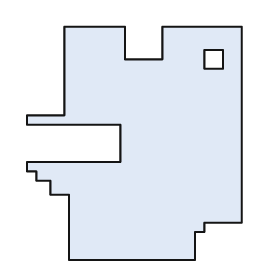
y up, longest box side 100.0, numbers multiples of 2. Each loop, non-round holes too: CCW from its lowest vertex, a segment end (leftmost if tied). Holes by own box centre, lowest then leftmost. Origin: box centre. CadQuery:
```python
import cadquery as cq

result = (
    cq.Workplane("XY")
    .moveTo(-28.0, -50.0)
    .lineTo(26.0, -50.0)
    .lineTo(26.0, -38.0)
    .lineTo(30.0, -38.0)
    .lineTo(30.0, -34.0)
    .lineTo(46.0, -34.0)
    .lineTo(46.0, 50.0)
    .lineTo(12.0, 50.0)
    .lineTo(12.0, 36.0)
    .lineTo(-4.0, 36.0)
    .lineTo(-4.0, 50.0)
    .lineTo(-30.0, 50.0)
    .lineTo(-30.0, 12.0)
    .lineTo(-46.0, 12.0)
    .lineTo(-46.0, 8.0)
    .lineTo(-6.0, 8.0)
    .lineTo(-6.0, -8.0)
    .lineTo(-46.0, -8.0)
    .lineTo(-46.0, -12.0)
    .lineTo(-42.0, -12.0)
    .lineTo(-42.0, -16.0)
    .lineTo(-36.0, -16.0)
    .lineTo(-36.0, -22.0)
    .lineTo(-28.0, -22.0)
    .close()
    .moveTo(30.0, 32.0)
    .lineTo(38.0, 32.0)
    .lineTo(38.0, 40.0)
    .lineTo(30.0, 40.0)
    .close()
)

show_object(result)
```